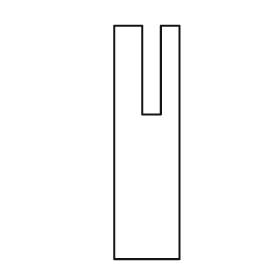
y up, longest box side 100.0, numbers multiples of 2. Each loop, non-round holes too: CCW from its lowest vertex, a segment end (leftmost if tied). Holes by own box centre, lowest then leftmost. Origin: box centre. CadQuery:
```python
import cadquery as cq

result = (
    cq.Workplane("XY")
    .moveTo(-14.0, -50.0)
    .lineTo(14.0, -50.0)
    .lineTo(14.0, 50.0)
    .lineTo(6.0, 50.0)
    .lineTo(6.0, 12.0)
    .lineTo(-2.0, 12.0)
    .lineTo(-2.0, 50.0)
    .lineTo(-14.0, 50.0)
    .close()
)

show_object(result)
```